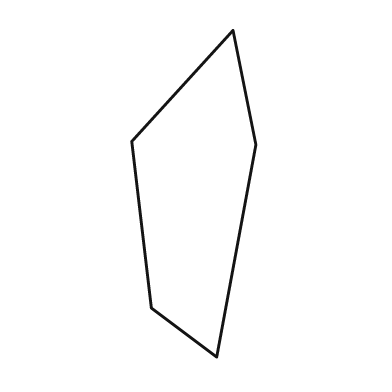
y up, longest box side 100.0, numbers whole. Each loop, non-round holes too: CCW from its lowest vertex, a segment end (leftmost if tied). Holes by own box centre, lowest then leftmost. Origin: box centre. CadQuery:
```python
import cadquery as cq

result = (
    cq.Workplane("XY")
    .moveTo(7.0, -50.0)
    .lineTo(19.0, 15.0)
    .lineTo(12.0, 50.0)
    .lineTo(-19.0, 16.0)
    .lineTo(-13.0, -35.0)
    .close()
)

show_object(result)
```